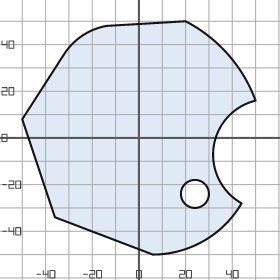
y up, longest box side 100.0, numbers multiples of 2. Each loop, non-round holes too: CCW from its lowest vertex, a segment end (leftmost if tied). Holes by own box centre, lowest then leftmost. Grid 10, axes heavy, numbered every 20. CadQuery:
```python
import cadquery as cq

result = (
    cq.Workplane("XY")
    .moveTo(6.0, -50.0)
    .threePointArc((28.0, -44.0), (44.0, -28.0))
    .threePointArc((32.0, -4.0), (50.0, 16.0))
    .threePointArc((38.0, 36.0), (20.0, 50.0))
    .lineTo(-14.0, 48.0)
    .threePointArc((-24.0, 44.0), (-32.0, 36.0))
    .lineTo(-50.0, 8.0)
    .lineTo(-36.0, -34.0)
    .close()
    .moveTo(24.0, -24.0)
    .circle(6.0)
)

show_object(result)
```